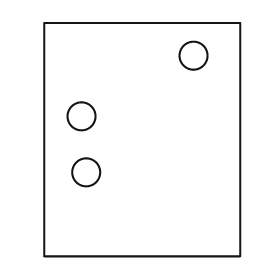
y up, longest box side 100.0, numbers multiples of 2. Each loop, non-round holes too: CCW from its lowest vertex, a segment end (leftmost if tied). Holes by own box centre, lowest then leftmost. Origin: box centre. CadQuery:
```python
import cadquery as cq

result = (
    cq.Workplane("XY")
    .moveTo(-42.0, -50.0)
    .lineTo(42.0, -50.0)
    .lineTo(42.0, 50.0)
    .lineTo(-42.0, 50.0)
    .close()
    .moveTo(-24.0, -14.0)
    .circle(6.0)
    .moveTo(-26.0, 10.0)
    .circle(6.0)
    .moveTo(22.0, 36.0)
    .circle(6.0)
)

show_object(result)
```